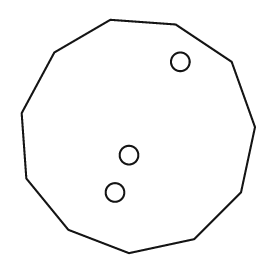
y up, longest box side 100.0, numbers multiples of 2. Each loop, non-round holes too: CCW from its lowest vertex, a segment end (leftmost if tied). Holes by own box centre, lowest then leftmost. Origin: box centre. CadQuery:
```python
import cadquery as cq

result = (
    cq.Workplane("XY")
    .moveTo(-4.0, -50.0)
    .lineTo(24.0, -44.0)
    .lineTo(44.0, -24.0)
    .lineTo(50.0, 4.0)
    .lineTo(40.0, 32.0)
    .lineTo(16.0, 48.0)
    .lineTo(-12.0, 50.0)
    .lineTo(-36.0, 36.0)
    .lineTo(-50.0, 10.0)
    .lineTo(-48.0, -18.0)
    .lineTo(-30.0, -40.0)
    .close()
    .moveTo(-10.0, -24.0)
    .circle(4.0)
    .moveTo(-4.0, -8.0)
    .circle(4.0)
    .moveTo(18.0, 32.0)
    .circle(4.0)
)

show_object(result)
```